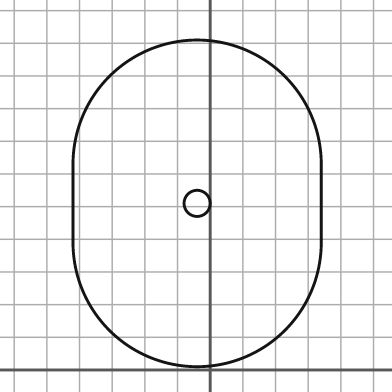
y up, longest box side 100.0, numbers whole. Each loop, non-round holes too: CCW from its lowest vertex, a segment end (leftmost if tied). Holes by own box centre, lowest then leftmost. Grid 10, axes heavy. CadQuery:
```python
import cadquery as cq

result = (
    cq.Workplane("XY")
    .moveTo(-42.0, 39.0)
    .threePointArc((-4.0, 1.0), (34.0, 39.0))
    .lineTo(34.0, 63.0)
    .threePointArc((-4.0, 101.0), (-42.0, 63.0))
    .close()
    .moveTo(-4.0, 51.0)
    .circle(4.0)
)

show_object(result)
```